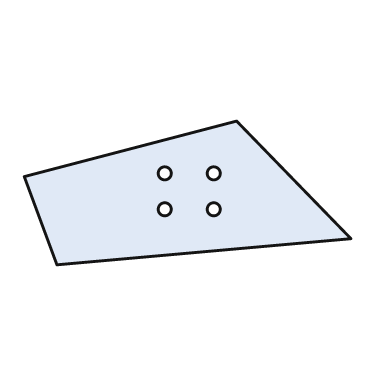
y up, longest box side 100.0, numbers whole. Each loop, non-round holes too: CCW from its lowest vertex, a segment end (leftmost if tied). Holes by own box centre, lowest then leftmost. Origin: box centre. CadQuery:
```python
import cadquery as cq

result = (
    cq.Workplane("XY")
    .moveTo(-40.0, -22.0)
    .lineTo(50.0, -14.0)
    .lineTo(15.0, 22.0)
    .lineTo(-50.0, 5.0)
    .close()
    .moveTo(-7.0, -5.0)
    .circle(2.0)
    .moveTo(8.0, -5.0)
    .circle(2.0)
    .moveTo(-7.0, 6.0)
    .circle(2.0)
    .moveTo(8.0, 6.0)
    .circle(2.0)
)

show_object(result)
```